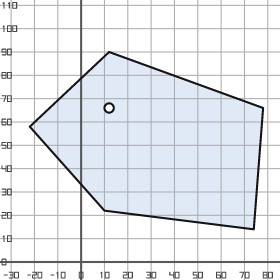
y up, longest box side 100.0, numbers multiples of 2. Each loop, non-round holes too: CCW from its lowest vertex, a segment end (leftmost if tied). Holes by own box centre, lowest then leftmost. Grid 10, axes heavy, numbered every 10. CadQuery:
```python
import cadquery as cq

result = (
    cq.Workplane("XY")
    .moveTo(74.0, 14.0)
    .lineTo(78.0, 66.0)
    .lineTo(12.0, 90.0)
    .lineTo(-22.0, 58.0)
    .lineTo(10.0, 22.0)
    .close()
    .moveTo(12.0, 66.0)
    .circle(2.0)
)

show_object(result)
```